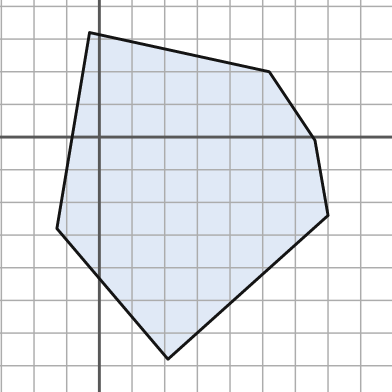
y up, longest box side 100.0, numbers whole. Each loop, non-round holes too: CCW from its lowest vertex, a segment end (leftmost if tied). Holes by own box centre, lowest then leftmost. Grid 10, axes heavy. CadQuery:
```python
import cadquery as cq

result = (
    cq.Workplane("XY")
    .moveTo(21.0, -68.0)
    .lineTo(70.0, -24.0)
    .lineTo(66.0, -1.0)
    .lineTo(52.0, 20.0)
    .lineTo(-3.0, 32.0)
    .lineTo(-13.0, -28.0)
    .close()
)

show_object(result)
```